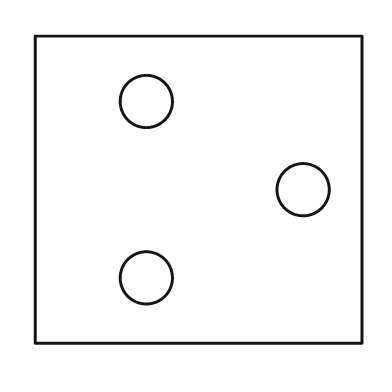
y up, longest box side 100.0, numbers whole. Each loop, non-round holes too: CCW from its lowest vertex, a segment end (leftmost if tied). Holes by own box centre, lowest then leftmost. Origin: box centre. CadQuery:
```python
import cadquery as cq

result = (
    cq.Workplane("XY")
    .moveTo(-50.0, -47.0)
    .lineTo(50.0, -47.0)
    .lineTo(50.0, 47.0)
    .lineTo(-50.0, 47.0)
    .close()
    .moveTo(-16.0, -27.0)
    .circle(8.0)
    .moveTo(32.0, 0.0)
    .circle(8.0)
    .moveTo(-16.0, 27.0)
    .circle(8.0)
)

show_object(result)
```